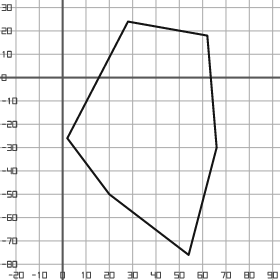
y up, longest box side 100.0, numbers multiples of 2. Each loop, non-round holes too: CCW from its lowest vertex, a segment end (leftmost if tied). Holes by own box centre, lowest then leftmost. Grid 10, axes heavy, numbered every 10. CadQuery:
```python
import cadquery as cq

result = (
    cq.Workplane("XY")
    .moveTo(54.0, -76.0)
    .lineTo(66.0, -30.0)
    .lineTo(62.0, 18.0)
    .lineTo(28.0, 24.0)
    .lineTo(2.0, -26.0)
    .lineTo(20.0, -50.0)
    .close()
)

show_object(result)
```